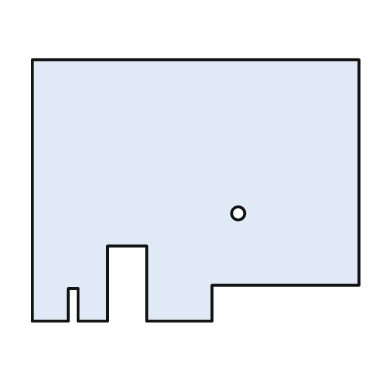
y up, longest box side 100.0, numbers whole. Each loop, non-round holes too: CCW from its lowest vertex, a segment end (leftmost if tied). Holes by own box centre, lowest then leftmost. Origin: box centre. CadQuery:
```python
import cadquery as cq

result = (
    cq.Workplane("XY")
    .moveTo(-50.0, -40.0)
    .lineTo(-39.0, -40.0)
    .lineTo(-39.0, -30.0)
    .lineTo(-36.0, -30.0)
    .lineTo(-36.0, -40.0)
    .lineTo(-27.0, -40.0)
    .lineTo(-27.0, -17.0)
    .lineTo(-15.0, -17.0)
    .lineTo(-15.0, -40.0)
    .lineTo(5.0, -40.0)
    .lineTo(5.0, -29.0)
    .lineTo(50.0, -29.0)
    .lineTo(50.0, 40.0)
    .lineTo(-50.0, 40.0)
    .close()
    .moveTo(13.0, -7.0)
    .circle(2.0)
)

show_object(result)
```